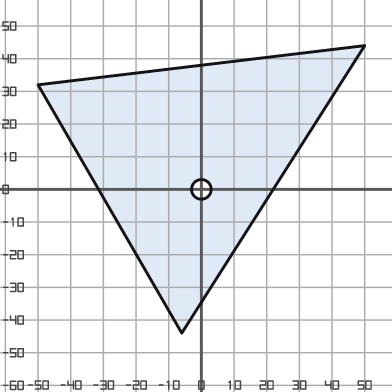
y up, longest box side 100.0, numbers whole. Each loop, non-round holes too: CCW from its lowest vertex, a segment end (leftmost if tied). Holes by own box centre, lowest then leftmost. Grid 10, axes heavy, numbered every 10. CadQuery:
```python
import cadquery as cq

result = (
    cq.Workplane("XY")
    .moveTo(-6.0, -44.0)
    .lineTo(50.0, 44.0)
    .lineTo(-50.0, 32.0)
    .close()
    .moveTo(0.0, 0.0)
    .circle(3.0)
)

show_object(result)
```